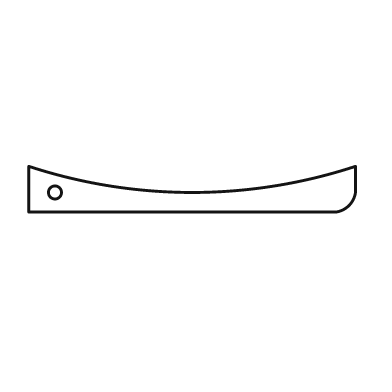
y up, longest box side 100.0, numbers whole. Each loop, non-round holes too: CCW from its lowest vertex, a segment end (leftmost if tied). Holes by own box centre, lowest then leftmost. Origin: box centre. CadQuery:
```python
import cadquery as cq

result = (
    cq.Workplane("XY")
    .moveTo(-50.0, -7.0)
    .lineTo(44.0, -7.0)
    .threePointArc((48.0, -5.0), (50.0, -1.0))
    .lineTo(50.0, 7.0)
    .threePointArc((0.0, -1.0), (-50.0, 7.0))
    .close()
    .moveTo(-42.0, -1.0)
    .circle(2.0)
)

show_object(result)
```